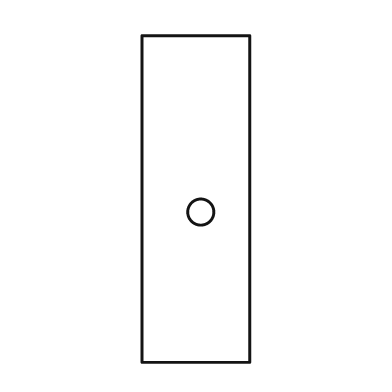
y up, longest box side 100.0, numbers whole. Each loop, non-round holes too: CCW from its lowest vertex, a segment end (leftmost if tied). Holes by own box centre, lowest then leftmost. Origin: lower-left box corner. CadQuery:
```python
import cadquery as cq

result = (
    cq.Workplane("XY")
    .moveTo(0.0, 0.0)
    .lineTo(33.0, 0.0)
    .lineTo(33.0, 100.0)
    .lineTo(0.0, 100.0)
    .close()
    .moveTo(18.0, 46.0)
    .circle(4.0)
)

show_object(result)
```